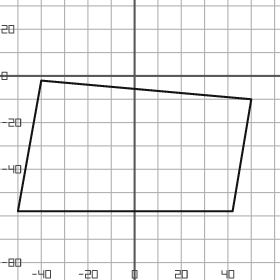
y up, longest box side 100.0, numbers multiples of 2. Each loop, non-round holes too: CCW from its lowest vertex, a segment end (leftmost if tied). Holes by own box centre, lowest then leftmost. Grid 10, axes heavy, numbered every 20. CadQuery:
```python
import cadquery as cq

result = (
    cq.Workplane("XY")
    .moveTo(-50.0, -58.0)
    .lineTo(42.0, -58.0)
    .lineTo(50.0, -10.0)
    .lineTo(-40.0, -2.0)
    .close()
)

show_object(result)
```